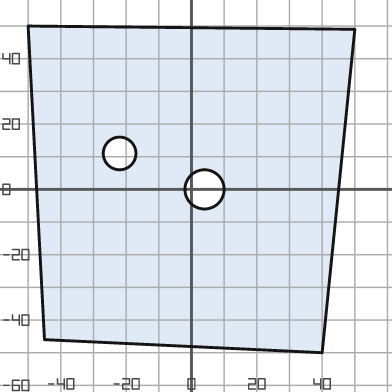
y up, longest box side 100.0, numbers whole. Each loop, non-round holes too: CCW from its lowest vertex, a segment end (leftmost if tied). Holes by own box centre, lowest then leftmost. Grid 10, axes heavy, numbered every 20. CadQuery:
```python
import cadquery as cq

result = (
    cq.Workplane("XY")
    .moveTo(40.0, -50.0)
    .lineTo(50.0, 49.0)
    .lineTo(-50.0, 50.0)
    .lineTo(-45.0, -46.0)
    .close()
    .moveTo(4.0, 0.0)
    .circle(6.0)
    .moveTo(-22.0, 11.0)
    .circle(5.0)
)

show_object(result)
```